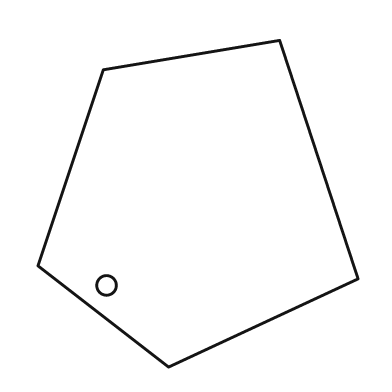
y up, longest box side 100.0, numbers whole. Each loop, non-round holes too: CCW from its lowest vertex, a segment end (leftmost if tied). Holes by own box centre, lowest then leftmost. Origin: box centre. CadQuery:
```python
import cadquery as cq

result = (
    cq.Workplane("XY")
    .moveTo(-9.0, -50.0)
    .lineTo(49.0, -23.0)
    .lineTo(25.0, 50.0)
    .lineTo(-29.0, 41.0)
    .lineTo(-49.0, -19.0)
    .close()
    .moveTo(-28.0, -25.0)
    .circle(3.0)
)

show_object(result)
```